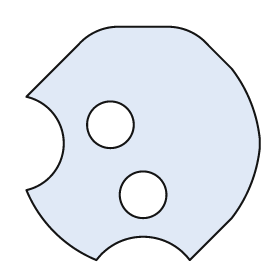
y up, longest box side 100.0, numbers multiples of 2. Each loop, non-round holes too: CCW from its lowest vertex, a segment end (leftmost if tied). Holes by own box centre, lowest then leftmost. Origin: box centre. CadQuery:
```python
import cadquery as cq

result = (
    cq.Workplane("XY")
    .moveTo(-20.0, -50.0)
    .threePointArc((0.0, -40.0), (20.0, -50.0))
    .lineTo(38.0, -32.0)
    .threePointArc((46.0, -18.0), (50.0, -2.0))
    .lineTo(50.0, 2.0)
    .threePointArc((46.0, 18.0), (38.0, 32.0))
    .lineTo(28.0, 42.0)
    .threePointArc((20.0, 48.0), (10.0, 50.0))
    .lineTo(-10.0, 50.0)
    .threePointArc((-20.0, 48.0), (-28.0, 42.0))
    .lineTo(-50.0, 20.0)
    .threePointArc((-34.0, 0.0), (-50.0, -20.0))
    .threePointArc((-38.0, -38.0), (-20.0, -50.0))
    .close()
    .moveTo(0.0, -22.0)
    .circle(10.0)
    .moveTo(-14.0, 8.0)
    .circle(10.0)
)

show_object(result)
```